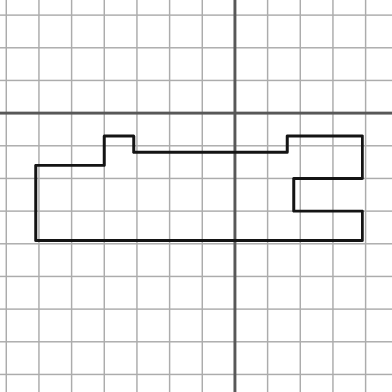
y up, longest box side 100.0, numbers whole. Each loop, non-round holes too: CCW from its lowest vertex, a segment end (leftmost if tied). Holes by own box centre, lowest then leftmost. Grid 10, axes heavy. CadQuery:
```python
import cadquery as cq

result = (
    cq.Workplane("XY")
    .moveTo(-61.0, -39.0)
    .lineTo(39.0, -39.0)
    .lineTo(39.0, -30.0)
    .lineTo(18.0, -30.0)
    .lineTo(18.0, -20.0)
    .lineTo(39.0, -20.0)
    .lineTo(39.0, -7.0)
    .lineTo(16.0, -7.0)
    .lineTo(16.0, -12.0)
    .lineTo(-31.0, -12.0)
    .lineTo(-31.0, -7.0)
    .lineTo(-40.0, -7.0)
    .lineTo(-40.0, -16.0)
    .lineTo(-61.0, -16.0)
    .close()
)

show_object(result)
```